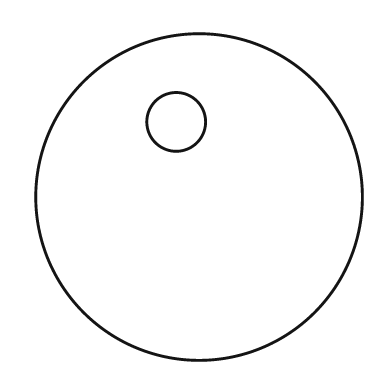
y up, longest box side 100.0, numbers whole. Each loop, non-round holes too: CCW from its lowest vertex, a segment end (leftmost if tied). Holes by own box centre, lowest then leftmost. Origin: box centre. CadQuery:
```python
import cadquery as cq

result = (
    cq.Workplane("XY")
    .moveTo(0.0, 0.0)
    .circle(50.0)
    .moveTo(-7.0, 23.0)
    .circle(9.0)
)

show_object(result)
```